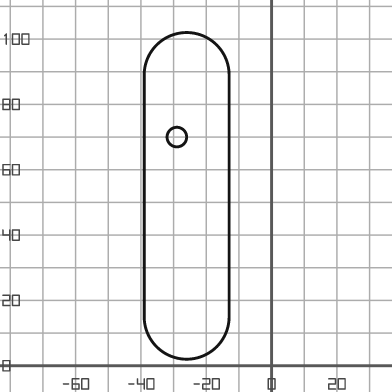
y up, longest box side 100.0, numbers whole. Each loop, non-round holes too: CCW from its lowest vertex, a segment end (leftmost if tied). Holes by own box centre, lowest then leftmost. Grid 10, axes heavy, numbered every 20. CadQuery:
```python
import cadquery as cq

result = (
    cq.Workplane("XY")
    .moveTo(-39.0, 15.0)
    .threePointArc((-26.0, 2.0), (-13.0, 15.0))
    .lineTo(-13.0, 89.0)
    .threePointArc((-26.0, 102.0), (-39.0, 89.0))
    .close()
    .moveTo(-29.0, 70.0)
    .circle(3.0)
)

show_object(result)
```